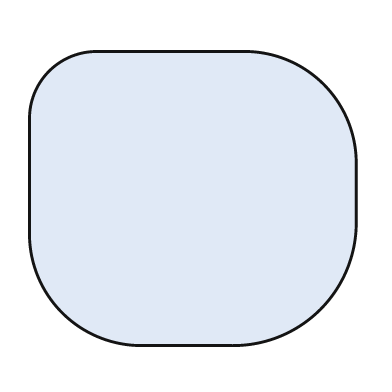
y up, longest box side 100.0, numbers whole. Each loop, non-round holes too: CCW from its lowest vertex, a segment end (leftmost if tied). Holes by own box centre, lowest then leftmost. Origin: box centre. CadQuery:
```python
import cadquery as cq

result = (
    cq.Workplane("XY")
    .moveTo(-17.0, -45.0)
    .lineTo(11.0, -45.0)
    .threePointArc((39.0, -34.0), (50.0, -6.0))
    .lineTo(50.0, 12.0)
    .threePointArc((40.0, 35.0), (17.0, 45.0))
    .lineTo(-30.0, 45.0)
    .threePointArc((-44.0, 39.0), (-50.0, 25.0))
    .lineTo(-50.0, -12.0)
    .threePointArc((-40.0, -35.0), (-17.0, -45.0))
    .close()
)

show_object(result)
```